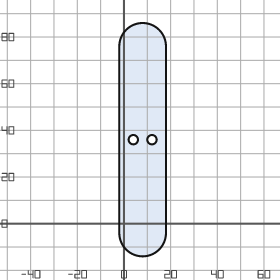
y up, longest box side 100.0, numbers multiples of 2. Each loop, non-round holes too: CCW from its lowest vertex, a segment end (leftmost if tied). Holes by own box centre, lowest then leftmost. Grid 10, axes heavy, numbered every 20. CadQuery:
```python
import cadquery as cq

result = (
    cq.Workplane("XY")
    .moveTo(-2.0, -4.0)
    .threePointArc((8.0, -14.0), (18.0, -4.0))
    .lineTo(18.0, 76.0)
    .threePointArc((8.0, 86.0), (-2.0, 76.0))
    .close()
    .moveTo(4.0, 36.0)
    .circle(2.0)
    .moveTo(12.0, 36.0)
    .circle(2.0)
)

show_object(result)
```